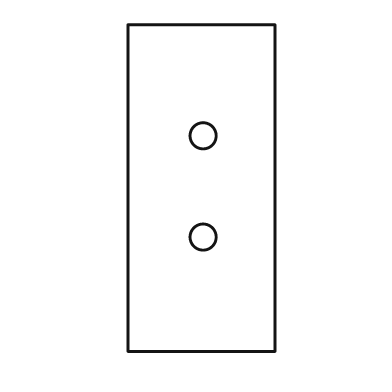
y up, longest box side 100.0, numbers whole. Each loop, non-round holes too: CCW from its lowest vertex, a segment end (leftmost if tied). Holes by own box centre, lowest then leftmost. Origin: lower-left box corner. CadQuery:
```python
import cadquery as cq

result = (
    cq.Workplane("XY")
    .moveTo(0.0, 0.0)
    .lineTo(45.0, 0.0)
    .lineTo(45.0, 100.0)
    .lineTo(0.0, 100.0)
    .close()
    .moveTo(23.0, 35.0)
    .circle(4.0)
    .moveTo(23.0, 66.0)
    .circle(4.0)
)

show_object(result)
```